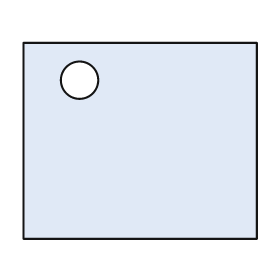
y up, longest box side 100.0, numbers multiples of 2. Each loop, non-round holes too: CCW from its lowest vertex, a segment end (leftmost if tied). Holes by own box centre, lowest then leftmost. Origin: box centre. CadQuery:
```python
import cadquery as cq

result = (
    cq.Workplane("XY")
    .moveTo(-50.0, -42.0)
    .lineTo(50.0, -42.0)
    .lineTo(50.0, 42.0)
    .lineTo(-50.0, 42.0)
    .close()
    .moveTo(-26.0, 26.0)
    .circle(8.0)
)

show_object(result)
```